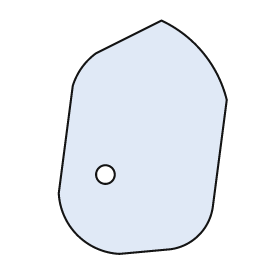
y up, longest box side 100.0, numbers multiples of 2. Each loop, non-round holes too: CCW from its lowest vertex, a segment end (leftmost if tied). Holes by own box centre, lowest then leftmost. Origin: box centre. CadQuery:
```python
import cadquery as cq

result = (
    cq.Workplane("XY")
    .moveTo(-10.0, -50.0)
    .lineTo(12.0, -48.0)
    .threePointArc((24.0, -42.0), (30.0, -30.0))
    .lineTo(36.0, 16.0)
    .threePointArc((26.0, 36.0), (8.0, 50.0))
    .lineTo(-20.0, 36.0)
    .threePointArc((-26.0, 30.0), (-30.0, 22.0))
    .lineTo(-36.0, -24.0)
    .threePointArc((-28.0, -42.0), (-10.0, -50.0))
    .close()
    .moveTo(-16.0, -16.0)
    .circle(4.0)
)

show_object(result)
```